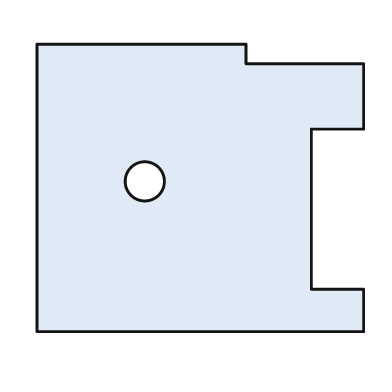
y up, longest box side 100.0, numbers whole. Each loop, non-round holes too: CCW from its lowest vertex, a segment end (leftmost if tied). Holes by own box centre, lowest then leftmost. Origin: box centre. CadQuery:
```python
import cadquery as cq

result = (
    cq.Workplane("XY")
    .moveTo(-50.0, -44.0)
    .lineTo(50.0, -44.0)
    .lineTo(50.0, -31.0)
    .lineTo(34.0, -31.0)
    .lineTo(34.0, 18.0)
    .lineTo(50.0, 18.0)
    .lineTo(50.0, 38.0)
    .lineTo(14.0, 38.0)
    .lineTo(14.0, 44.0)
    .lineTo(-50.0, 44.0)
    .close()
    .moveTo(-17.0, 2.0)
    .circle(6.0)
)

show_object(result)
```